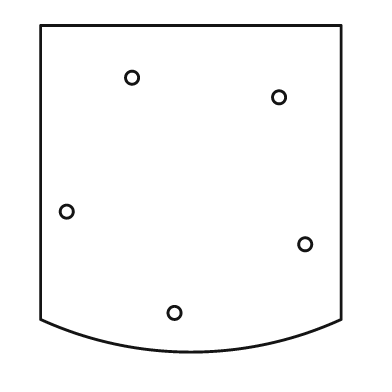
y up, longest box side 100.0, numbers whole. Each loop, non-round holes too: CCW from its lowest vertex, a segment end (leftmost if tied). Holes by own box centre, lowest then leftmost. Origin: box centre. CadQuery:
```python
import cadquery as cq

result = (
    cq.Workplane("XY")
    .moveTo(-46.0, -40.0)
    .threePointArc((0.0, -50.0), (46.0, -40.0))
    .lineTo(46.0, 50.0)
    .lineTo(-46.0, 50.0)
    .close()
    .moveTo(-5.0, -38.0)
    .circle(2.0)
    .moveTo(35.0, -17.0)
    .circle(2.0)
    .moveTo(-38.0, -7.0)
    .circle(2.0)
    .moveTo(27.0, 28.0)
    .circle(2.0)
    .moveTo(-18.0, 34.0)
    .circle(2.0)
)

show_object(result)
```